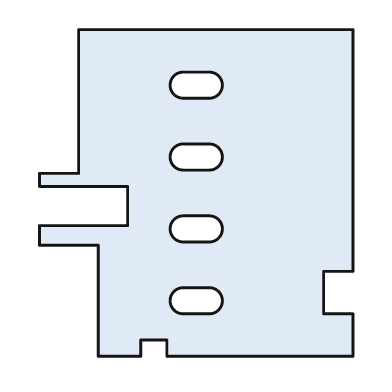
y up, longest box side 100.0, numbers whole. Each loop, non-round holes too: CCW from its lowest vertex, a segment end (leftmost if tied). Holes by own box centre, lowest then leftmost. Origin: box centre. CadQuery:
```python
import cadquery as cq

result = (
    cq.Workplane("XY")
    .moveTo(-30.0, -50.0)
    .lineTo(-17.0, -50.0)
    .lineTo(-17.0, -45.0)
    .lineTo(-9.0, -45.0)
    .lineTo(-9.0, -50.0)
    .lineTo(48.0, -50.0)
    .lineTo(48.0, -37.0)
    .lineTo(39.0, -37.0)
    .lineTo(39.0, -24.0)
    .lineTo(48.0, -24.0)
    .lineTo(48.0, 50.0)
    .lineTo(-36.0, 50.0)
    .lineTo(-36.0, 6.0)
    .lineTo(-48.0, 6.0)
    .lineTo(-48.0, 2.0)
    .lineTo(-21.0, 2.0)
    .lineTo(-21.0, -10.0)
    .lineTo(-48.0, -10.0)
    .lineTo(-48.0, -16.0)
    .lineTo(-30.0, -16.0)
    .close()
    .moveTo(-4.0, -37.0)
    .lineTo(4.0, -37.0)
    .threePointArc((8.0, -33.0), (4.0, -29.0))
    .lineTo(-4.0, -29.0)
    .threePointArc((-8.0, -33.0), (-4.0, -37.0))
    .close()
    .moveTo(-4.0, -15.0)
    .lineTo(4.0, -15.0)
    .threePointArc((8.0, -11.0), (4.0, -7.0))
    .lineTo(-4.0, -7.0)
    .threePointArc((-8.0, -11.0), (-4.0, -15.0))
    .close()
    .moveTo(-4.0, 7.0)
    .lineTo(4.0, 7.0)
    .threePointArc((8.0, 11.0), (4.0, 15.0))
    .lineTo(-4.0, 15.0)
    .threePointArc((-8.0, 11.0), (-4.0, 7.0))
    .close()
    .moveTo(-4.0, 29.0)
    .lineTo(4.0, 29.0)
    .threePointArc((8.0, 33.0), (4.0, 37.0))
    .lineTo(-4.0, 37.0)
    .threePointArc((-8.0, 33.0), (-4.0, 29.0))
    .close()
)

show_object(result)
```